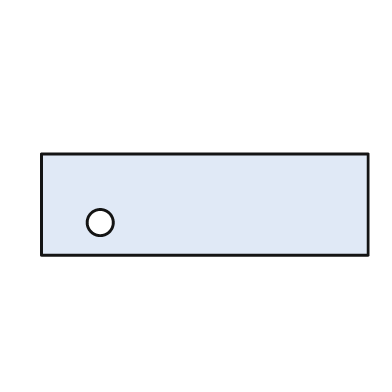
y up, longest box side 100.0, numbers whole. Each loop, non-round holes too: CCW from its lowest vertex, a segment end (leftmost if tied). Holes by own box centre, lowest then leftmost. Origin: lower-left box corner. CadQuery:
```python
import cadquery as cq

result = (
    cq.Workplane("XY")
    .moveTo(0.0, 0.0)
    .lineTo(100.0, 0.0)
    .lineTo(100.0, 31.0)
    .lineTo(0.0, 31.0)
    .close()
    .moveTo(18.0, 10.0)
    .circle(4.0)
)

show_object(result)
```